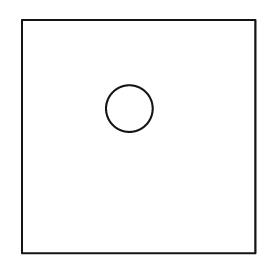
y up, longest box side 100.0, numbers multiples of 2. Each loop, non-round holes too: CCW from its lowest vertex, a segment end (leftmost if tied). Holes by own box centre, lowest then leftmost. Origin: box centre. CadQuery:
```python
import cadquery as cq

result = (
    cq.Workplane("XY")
    .moveTo(-50.0, -50.0)
    .lineTo(50.0, -50.0)
    .lineTo(50.0, 50.0)
    .lineTo(-50.0, 50.0)
    .close()
    .moveTo(-4.0, 12.0)
    .circle(10.0)
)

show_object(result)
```